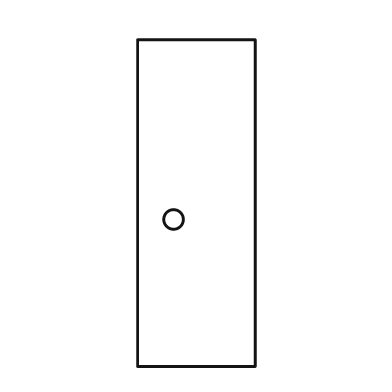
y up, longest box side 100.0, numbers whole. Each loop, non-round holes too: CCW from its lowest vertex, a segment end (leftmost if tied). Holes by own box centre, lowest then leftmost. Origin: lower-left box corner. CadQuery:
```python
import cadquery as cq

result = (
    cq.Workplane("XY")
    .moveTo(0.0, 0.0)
    .lineTo(36.0, 0.0)
    .lineTo(36.0, 100.0)
    .lineTo(0.0, 100.0)
    .close()
    .moveTo(11.0, 45.0)
    .circle(3.0)
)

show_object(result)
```